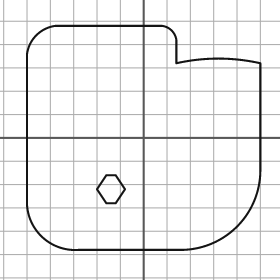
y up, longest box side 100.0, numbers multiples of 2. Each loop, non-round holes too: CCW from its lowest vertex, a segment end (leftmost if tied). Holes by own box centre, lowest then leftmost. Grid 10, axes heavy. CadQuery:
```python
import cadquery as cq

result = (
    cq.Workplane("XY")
    .moveTo(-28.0, -48.0)
    .lineTo(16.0, -48.0)
    .threePointArc((40.0, -38.0), (50.0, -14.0))
    .lineTo(50.0, 32.0)
    .threePointArc((32.0, 34.0), (14.0, 32.0))
    .lineTo(14.0, 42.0)
    .threePointArc((12.0, 46.0), (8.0, 48.0))
    .lineTo(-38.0, 48.0)
    .threePointArc((-46.0, 44.0), (-50.0, 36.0))
    .lineTo(-50.0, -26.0)
    .threePointArc((-44.0, -42.0), (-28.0, -48.0))
    .close()
    .moveTo(-16.0, -28.0)
    .lineTo(-12.0, -28.0)
    .lineTo(-8.0, -22.0)
    .lineTo(-12.0, -16.0)
    .lineTo(-16.0, -16.0)
    .lineTo(-20.0, -22.0)
    .close()
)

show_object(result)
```